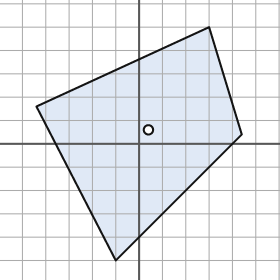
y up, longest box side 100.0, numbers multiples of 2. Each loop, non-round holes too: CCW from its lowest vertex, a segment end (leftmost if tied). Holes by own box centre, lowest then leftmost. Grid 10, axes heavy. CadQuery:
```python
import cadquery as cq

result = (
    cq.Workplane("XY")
    .moveTo(-10.0, -50.0)
    .lineTo(44.0, 4.0)
    .lineTo(30.0, 50.0)
    .lineTo(-44.0, 16.0)
    .close()
    .moveTo(4.0, 6.0)
    .circle(2.0)
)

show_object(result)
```